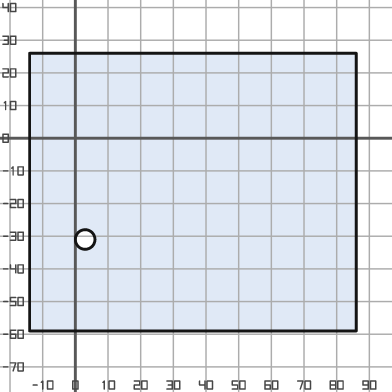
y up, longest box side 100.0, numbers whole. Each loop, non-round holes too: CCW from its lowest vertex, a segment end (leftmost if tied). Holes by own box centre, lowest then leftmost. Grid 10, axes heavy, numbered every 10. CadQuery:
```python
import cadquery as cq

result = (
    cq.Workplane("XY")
    .moveTo(-14.0, -59.0)
    .lineTo(86.0, -59.0)
    .lineTo(86.0, 26.0)
    .lineTo(-14.0, 26.0)
    .close()
    .moveTo(3.0, -31.0)
    .circle(3.0)
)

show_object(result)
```